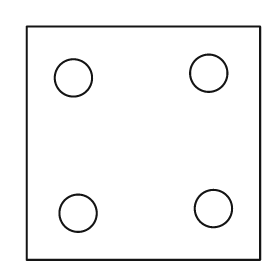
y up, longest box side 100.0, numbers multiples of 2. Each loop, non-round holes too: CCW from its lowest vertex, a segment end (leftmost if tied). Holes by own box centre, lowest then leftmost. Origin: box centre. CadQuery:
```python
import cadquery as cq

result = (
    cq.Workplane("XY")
    .moveTo(-50.0, -50.0)
    .lineTo(50.0, -50.0)
    .lineTo(50.0, 50.0)
    .lineTo(-50.0, 50.0)
    .close()
    .moveTo(-28.0, -30.0)
    .circle(8.0)
    .moveTo(30.0, -28.0)
    .circle(8.0)
    .moveTo(-30.0, 28.0)
    .circle(8.0)
    .moveTo(28.0, 30.0)
    .circle(8.0)
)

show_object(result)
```